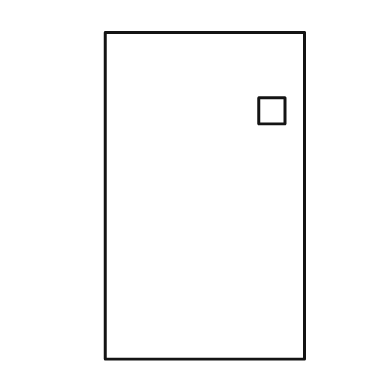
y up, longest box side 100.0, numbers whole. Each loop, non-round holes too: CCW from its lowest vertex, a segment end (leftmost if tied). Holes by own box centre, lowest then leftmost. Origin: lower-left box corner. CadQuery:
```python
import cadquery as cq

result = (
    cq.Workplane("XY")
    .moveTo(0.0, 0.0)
    .lineTo(61.0, 0.0)
    .lineTo(61.0, 100.0)
    .lineTo(0.0, 100.0)
    .close()
    .moveTo(47.0, 72.0)
    .lineTo(55.0, 72.0)
    .lineTo(55.0, 80.0)
    .lineTo(47.0, 80.0)
    .close()
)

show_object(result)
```